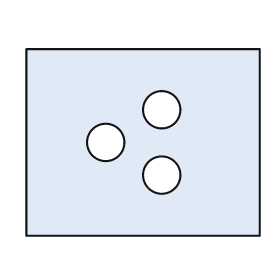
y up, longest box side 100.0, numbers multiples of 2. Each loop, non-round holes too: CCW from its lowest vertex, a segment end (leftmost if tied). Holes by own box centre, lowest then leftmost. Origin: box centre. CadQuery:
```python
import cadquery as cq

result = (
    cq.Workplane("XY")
    .moveTo(-50.0, -40.0)
    .lineTo(50.0, -40.0)
    .lineTo(50.0, 40.0)
    .lineTo(-50.0, 40.0)
    .close()
    .moveTo(8.0, -14.0)
    .circle(8.0)
    .moveTo(-16.0, 0.0)
    .circle(8.0)
    .moveTo(8.0, 14.0)
    .circle(8.0)
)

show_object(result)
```